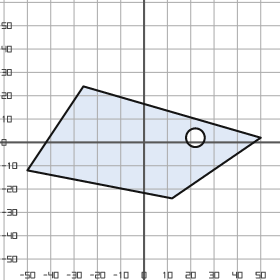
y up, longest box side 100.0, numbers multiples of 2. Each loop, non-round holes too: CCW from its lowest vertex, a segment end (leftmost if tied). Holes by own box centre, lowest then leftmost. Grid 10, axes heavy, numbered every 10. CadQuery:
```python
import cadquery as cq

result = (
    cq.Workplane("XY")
    .moveTo(12.0, -24.0)
    .lineTo(50.0, 2.0)
    .lineTo(-26.0, 24.0)
    .lineTo(-50.0, -12.0)
    .close()
    .moveTo(22.0, 2.0)
    .circle(4.0)
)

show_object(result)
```